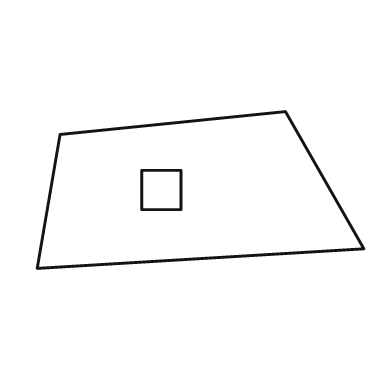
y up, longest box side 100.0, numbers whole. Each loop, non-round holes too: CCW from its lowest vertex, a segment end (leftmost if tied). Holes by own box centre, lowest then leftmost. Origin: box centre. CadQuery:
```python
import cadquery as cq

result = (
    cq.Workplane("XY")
    .moveTo(-50.0, -24.0)
    .lineTo(50.0, -18.0)
    .lineTo(26.0, 24.0)
    .lineTo(-43.0, 17.0)
    .close()
    .moveTo(-18.0, -6.0)
    .lineTo(-6.0, -6.0)
    .lineTo(-6.0, 6.0)
    .lineTo(-18.0, 6.0)
    .close()
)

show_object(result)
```